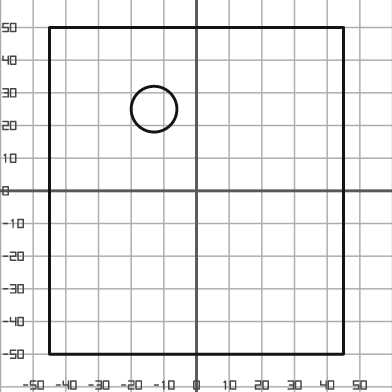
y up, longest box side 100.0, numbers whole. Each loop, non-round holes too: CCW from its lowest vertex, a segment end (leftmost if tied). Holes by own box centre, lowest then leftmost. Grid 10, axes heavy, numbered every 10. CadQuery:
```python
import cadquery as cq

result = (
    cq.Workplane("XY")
    .moveTo(-45.0, -50.0)
    .lineTo(45.0, -50.0)
    .lineTo(45.0, 50.0)
    .lineTo(-45.0, 50.0)
    .close()
    .moveTo(-13.0, 25.0)
    .circle(7.0)
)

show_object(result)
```